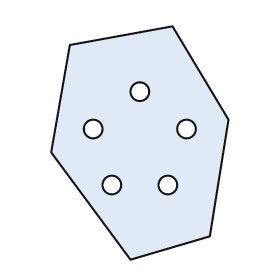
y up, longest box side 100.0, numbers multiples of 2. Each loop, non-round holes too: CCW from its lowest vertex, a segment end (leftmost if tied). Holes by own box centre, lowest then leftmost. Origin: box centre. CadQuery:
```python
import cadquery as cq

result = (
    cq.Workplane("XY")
    .moveTo(-4.0, -50.0)
    .lineTo(30.0, -40.0)
    .lineTo(38.0, 10.0)
    .lineTo(14.0, 50.0)
    .lineTo(-30.0, 42.0)
    .lineTo(-38.0, -4.0)
    .close()
    .moveTo(-12.0, -18.0)
    .circle(4.0)
    .moveTo(12.0, -18.0)
    .circle(4.0)
    .moveTo(-20.0, 6.0)
    .circle(4.0)
    .moveTo(20.0, 6.0)
    .circle(4.0)
    .moveTo(0.0, 22.0)
    .circle(4.0)
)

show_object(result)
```